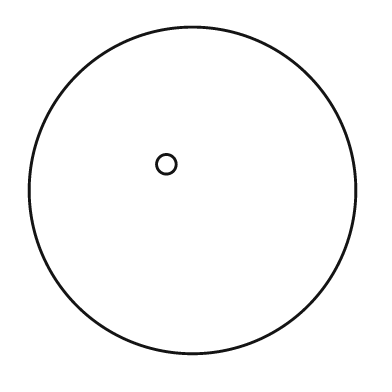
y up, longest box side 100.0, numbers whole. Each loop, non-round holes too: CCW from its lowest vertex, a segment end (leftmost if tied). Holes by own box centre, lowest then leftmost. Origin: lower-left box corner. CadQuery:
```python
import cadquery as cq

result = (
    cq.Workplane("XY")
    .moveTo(50.0, 50.0)
    .circle(50.0)
    .moveTo(42.0, 58.0)
    .circle(3.0)
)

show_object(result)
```